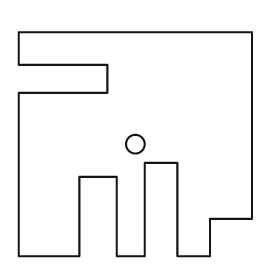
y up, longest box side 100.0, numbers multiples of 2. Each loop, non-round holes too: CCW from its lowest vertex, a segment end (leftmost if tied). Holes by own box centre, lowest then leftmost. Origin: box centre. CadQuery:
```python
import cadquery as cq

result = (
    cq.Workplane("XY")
    .moveTo(-50.0, -48.0)
    .lineTo(-24.0, -48.0)
    .lineTo(-24.0, -14.0)
    .lineTo(-8.0, -14.0)
    .lineTo(-8.0, -48.0)
    .lineTo(4.0, -48.0)
    .lineTo(4.0, -8.0)
    .lineTo(18.0, -8.0)
    .lineTo(18.0, -48.0)
    .lineTo(32.0, -48.0)
    .lineTo(32.0, -32.0)
    .lineTo(50.0, -32.0)
    .lineTo(50.0, 48.0)
    .lineTo(-50.0, 48.0)
    .lineTo(-50.0, 34.0)
    .lineTo(-12.0, 34.0)
    .lineTo(-12.0, 22.0)
    .lineTo(-50.0, 22.0)
    .close()
    .moveTo(0.0, 0.0)
    .circle(4.0)
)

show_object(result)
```